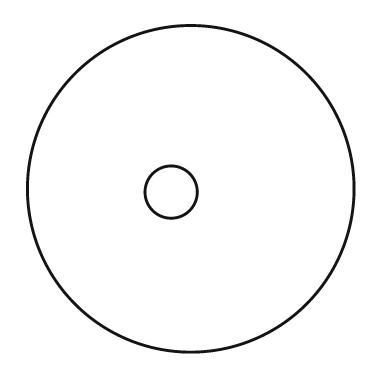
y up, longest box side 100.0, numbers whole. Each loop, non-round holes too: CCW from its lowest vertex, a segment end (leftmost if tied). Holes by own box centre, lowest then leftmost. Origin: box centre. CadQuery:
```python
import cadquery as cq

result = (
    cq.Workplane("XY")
    .moveTo(0.0, 0.0)
    .circle(50.0)
    .moveTo(-6.0, -1.0)
    .circle(8.0)
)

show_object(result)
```